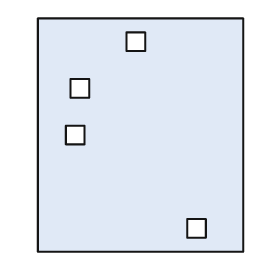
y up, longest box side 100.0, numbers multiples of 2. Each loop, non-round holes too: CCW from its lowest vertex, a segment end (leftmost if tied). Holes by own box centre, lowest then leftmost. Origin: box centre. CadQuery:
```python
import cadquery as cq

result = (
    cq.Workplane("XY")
    .moveTo(-44.0, -50.0)
    .lineTo(44.0, -50.0)
    .lineTo(44.0, 50.0)
    .lineTo(-44.0, 50.0)
    .close()
    .moveTo(20.0, -44.0)
    .lineTo(28.0, -44.0)
    .lineTo(28.0, -36.0)
    .lineTo(20.0, -36.0)
    .close()
    .moveTo(-32.0, -4.0)
    .lineTo(-24.0, -4.0)
    .lineTo(-24.0, 4.0)
    .lineTo(-32.0, 4.0)
    .close()
    .moveTo(-30.0, 16.0)
    .lineTo(-22.0, 16.0)
    .lineTo(-22.0, 24.0)
    .lineTo(-30.0, 24.0)
    .close()
    .moveTo(-6.0, 36.0)
    .lineTo(2.0, 36.0)
    .lineTo(2.0, 44.0)
    .lineTo(-6.0, 44.0)
    .close()
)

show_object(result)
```